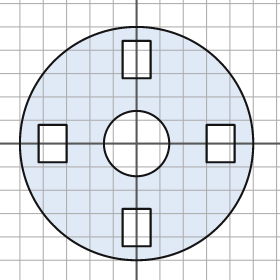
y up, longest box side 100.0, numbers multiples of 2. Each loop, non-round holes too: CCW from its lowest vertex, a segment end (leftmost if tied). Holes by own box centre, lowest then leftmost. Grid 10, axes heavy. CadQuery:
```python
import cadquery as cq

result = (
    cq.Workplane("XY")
    .moveTo(0.0, 0.0)
    .circle(50.0)
    .moveTo(-6.0, -44.0)
    .lineTo(6.0, -44.0)
    .lineTo(6.0, -28.0)
    .lineTo(-6.0, -28.0)
    .close()
    .moveTo(-42.0, -8.0)
    .lineTo(-30.0, -8.0)
    .lineTo(-30.0, 8.0)
    .lineTo(-42.0, 8.0)
    .close()
    .moveTo(0.0, 0.0)
    .circle(14.0)
    .moveTo(30.0, -8.0)
    .lineTo(42.0, -8.0)
    .lineTo(42.0, 8.0)
    .lineTo(30.0, 8.0)
    .close()
    .moveTo(-6.0, 28.0)
    .lineTo(6.0, 28.0)
    .lineTo(6.0, 44.0)
    .lineTo(-6.0, 44.0)
    .close()
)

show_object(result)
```